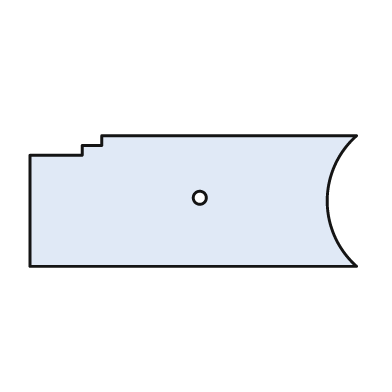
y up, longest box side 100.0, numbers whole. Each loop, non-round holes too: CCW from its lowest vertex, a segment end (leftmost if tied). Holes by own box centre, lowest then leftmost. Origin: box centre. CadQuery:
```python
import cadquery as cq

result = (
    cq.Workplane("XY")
    .moveTo(-50.0, -20.0)
    .lineTo(50.0, -20.0)
    .threePointArc((41.0, 0.0), (50.0, 20.0))
    .lineTo(-28.0, 20.0)
    .lineTo(-28.0, 17.0)
    .lineTo(-34.0, 17.0)
    .lineTo(-34.0, 14.0)
    .lineTo(-50.0, 14.0)
    .close()
    .moveTo(2.0, 1.0)
    .circle(2.0)
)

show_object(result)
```